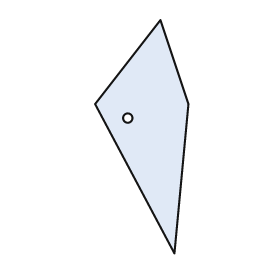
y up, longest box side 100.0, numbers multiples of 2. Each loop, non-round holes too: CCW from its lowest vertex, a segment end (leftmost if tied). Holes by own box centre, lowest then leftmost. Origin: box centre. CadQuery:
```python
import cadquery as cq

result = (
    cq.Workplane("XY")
    .moveTo(14.0, -50.0)
    .lineTo(20.0, 14.0)
    .lineTo(8.0, 50.0)
    .lineTo(-20.0, 14.0)
    .close()
    .moveTo(-6.0, 8.0)
    .circle(2.0)
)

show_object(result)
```